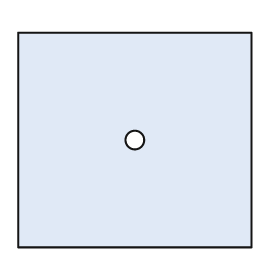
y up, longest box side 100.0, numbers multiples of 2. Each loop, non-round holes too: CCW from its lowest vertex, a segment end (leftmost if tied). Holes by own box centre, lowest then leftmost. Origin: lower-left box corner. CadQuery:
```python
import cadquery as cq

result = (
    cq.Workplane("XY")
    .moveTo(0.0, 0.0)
    .lineTo(100.0, 0.0)
    .lineTo(100.0, 92.0)
    .lineTo(0.0, 92.0)
    .close()
    .moveTo(50.0, 46.0)
    .circle(4.0)
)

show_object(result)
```